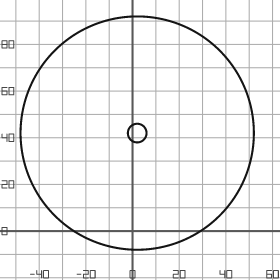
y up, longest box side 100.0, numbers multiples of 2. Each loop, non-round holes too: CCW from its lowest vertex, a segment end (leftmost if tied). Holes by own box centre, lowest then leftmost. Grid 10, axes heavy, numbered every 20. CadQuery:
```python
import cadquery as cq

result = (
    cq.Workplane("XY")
    .moveTo(2.0, 42.0)
    .circle(50.0)
    .moveTo(2.0, 42.0)
    .circle(4.0)
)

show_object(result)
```